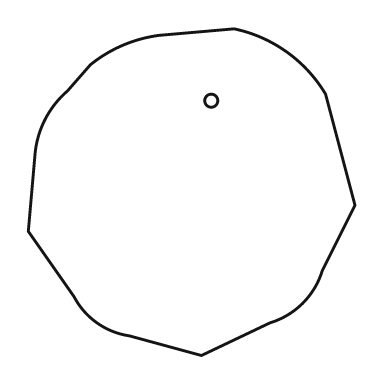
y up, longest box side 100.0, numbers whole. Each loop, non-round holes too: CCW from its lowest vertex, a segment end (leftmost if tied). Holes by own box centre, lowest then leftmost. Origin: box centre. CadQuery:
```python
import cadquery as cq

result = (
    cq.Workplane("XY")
    .moveTo(3.0, -50.0)
    .lineTo(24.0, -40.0)
    .threePointArc((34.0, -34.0), (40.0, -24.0))
    .lineTo(50.0, -4.0)
    .lineTo(41.0, 30.0)
    .threePointArc((29.0, 43.0), (13.0, 50.0))
    .lineTo(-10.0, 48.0)
    .threePointArc((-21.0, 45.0), (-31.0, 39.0))
    .lineTo(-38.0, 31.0)
    .threePointArc((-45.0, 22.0), (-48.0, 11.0))
    .lineTo(-50.0, -12.0)
    .lineTo(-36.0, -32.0)
    .threePointArc((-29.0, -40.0), (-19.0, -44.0))
    .close()
    .moveTo(6.0, 28.0)
    .circle(2.0)
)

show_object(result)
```